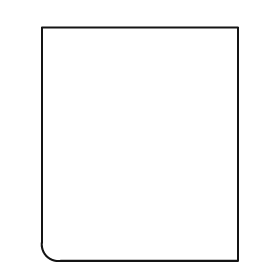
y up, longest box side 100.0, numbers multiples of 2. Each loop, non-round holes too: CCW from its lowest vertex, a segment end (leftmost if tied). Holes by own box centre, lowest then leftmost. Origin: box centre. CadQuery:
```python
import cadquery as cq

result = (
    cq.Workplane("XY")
    .moveTo(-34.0, -50.0)
    .lineTo(42.0, -50.0)
    .lineTo(42.0, 50.0)
    .lineTo(-42.0, 50.0)
    .lineTo(-42.0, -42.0)
    .threePointArc((-40.0, -48.0), (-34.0, -50.0))
    .close()
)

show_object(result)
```